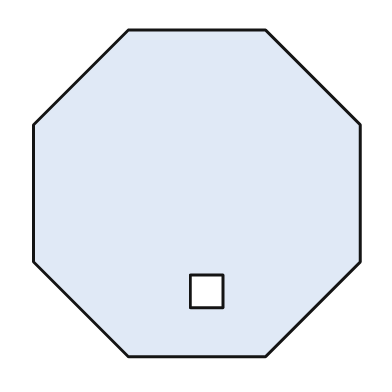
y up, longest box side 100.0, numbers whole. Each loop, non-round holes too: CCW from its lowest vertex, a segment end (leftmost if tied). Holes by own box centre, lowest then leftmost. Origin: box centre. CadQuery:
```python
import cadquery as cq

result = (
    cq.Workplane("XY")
    .moveTo(-21.0, -50.0)
    .lineTo(21.0, -50.0)
    .lineTo(50.0, -21.0)
    .lineTo(50.0, 21.0)
    .lineTo(21.0, 50.0)
    .lineTo(-21.0, 50.0)
    .lineTo(-50.0, 21.0)
    .lineTo(-50.0, -21.0)
    .close()
    .moveTo(-2.0, -35.0)
    .lineTo(8.0, -35.0)
    .lineTo(8.0, -25.0)
    .lineTo(-2.0, -25.0)
    .close()
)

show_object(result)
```